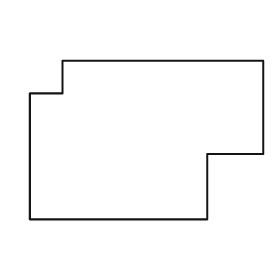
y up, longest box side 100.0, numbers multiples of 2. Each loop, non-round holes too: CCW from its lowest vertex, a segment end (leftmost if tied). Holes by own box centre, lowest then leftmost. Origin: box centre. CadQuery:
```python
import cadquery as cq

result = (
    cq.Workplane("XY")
    .moveTo(-50.0, -34.0)
    .lineTo(26.0, -34.0)
    .lineTo(26.0, -6.0)
    .lineTo(50.0, -6.0)
    .lineTo(50.0, 34.0)
    .lineTo(-36.0, 34.0)
    .lineTo(-36.0, 20.0)
    .lineTo(-50.0, 20.0)
    .close()
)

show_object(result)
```